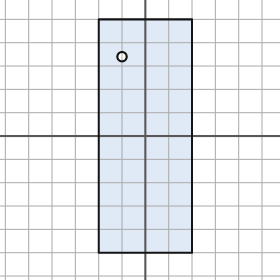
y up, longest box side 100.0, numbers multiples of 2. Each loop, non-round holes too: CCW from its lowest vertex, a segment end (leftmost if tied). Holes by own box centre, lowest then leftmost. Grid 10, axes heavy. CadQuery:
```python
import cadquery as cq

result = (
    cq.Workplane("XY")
    .moveTo(-20.0, -50.0)
    .lineTo(20.0, -50.0)
    .lineTo(20.0, 50.0)
    .lineTo(-20.0, 50.0)
    .close()
    .moveTo(-10.0, 34.0)
    .circle(2.0)
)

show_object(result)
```